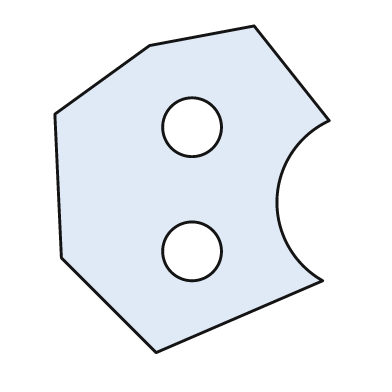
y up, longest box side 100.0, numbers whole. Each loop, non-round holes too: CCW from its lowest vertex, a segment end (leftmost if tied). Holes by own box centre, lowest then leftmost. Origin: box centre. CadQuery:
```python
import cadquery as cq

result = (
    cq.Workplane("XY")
    .moveTo(-11.0, -50.0)
    .lineTo(40.0, -28.0)
    .threePointArc((26.0, -3.0), (42.0, 21.0))
    .lineTo(19.0, 50.0)
    .lineTo(-13.0, 44.0)
    .lineTo(-42.0, 23.0)
    .lineTo(-40.0, -21.0)
    .close()
    .moveTo(0.0, -19.0)
    .circle(9.0)
    .moveTo(0.0, 19.0)
    .circle(9.0)
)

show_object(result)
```